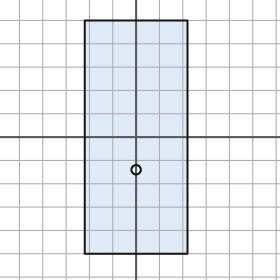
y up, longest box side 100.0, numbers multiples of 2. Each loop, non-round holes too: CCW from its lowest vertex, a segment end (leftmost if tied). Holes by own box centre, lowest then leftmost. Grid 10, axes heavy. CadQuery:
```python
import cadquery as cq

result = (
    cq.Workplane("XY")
    .moveTo(-22.0, -50.0)
    .lineTo(22.0, -50.0)
    .lineTo(22.0, 50.0)
    .lineTo(-22.0, 50.0)
    .close()
    .moveTo(0.0, -14.0)
    .circle(2.0)
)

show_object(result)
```